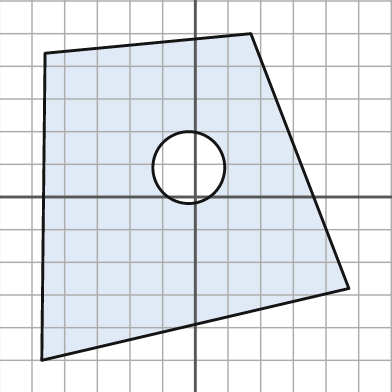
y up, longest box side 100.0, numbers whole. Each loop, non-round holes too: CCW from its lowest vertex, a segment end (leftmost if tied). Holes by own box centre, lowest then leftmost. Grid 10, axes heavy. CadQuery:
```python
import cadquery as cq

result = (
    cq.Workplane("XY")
    .moveTo(-47.0, -50.0)
    .lineTo(47.0, -28.0)
    .lineTo(17.0, 50.0)
    .lineTo(-46.0, 44.0)
    .close()
    .moveTo(-2.0, 9.0)
    .circle(11.0)
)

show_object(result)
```